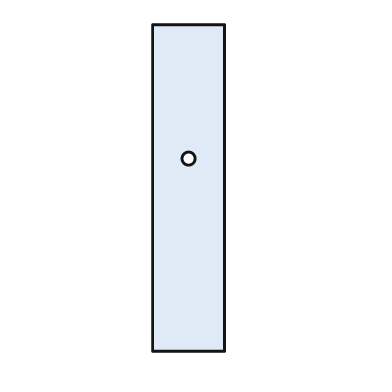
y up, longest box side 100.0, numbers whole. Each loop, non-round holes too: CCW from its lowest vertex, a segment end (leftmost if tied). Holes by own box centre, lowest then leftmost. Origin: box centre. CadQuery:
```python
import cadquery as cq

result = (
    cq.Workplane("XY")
    .moveTo(-11.0, -50.0)
    .lineTo(11.0, -50.0)
    .lineTo(11.0, 50.0)
    .lineTo(-11.0, 50.0)
    .close()
    .moveTo(0.0, 9.0)
    .circle(2.0)
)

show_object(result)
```